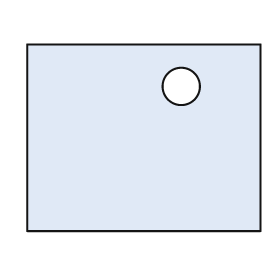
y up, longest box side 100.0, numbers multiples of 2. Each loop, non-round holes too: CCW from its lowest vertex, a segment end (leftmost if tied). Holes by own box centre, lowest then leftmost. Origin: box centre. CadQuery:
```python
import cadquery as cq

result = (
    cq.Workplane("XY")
    .moveTo(-50.0, -40.0)
    .lineTo(50.0, -40.0)
    .lineTo(50.0, 40.0)
    .lineTo(-50.0, 40.0)
    .close()
    .moveTo(16.0, 22.0)
    .circle(8.0)
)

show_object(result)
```